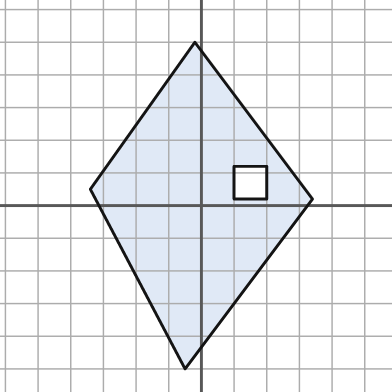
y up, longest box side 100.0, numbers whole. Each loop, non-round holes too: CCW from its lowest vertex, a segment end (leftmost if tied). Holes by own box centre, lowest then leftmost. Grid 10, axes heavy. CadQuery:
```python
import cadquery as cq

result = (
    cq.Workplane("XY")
    .moveTo(-5.0, -50.0)
    .lineTo(34.0, 2.0)
    .lineTo(-2.0, 50.0)
    .lineTo(-34.0, 5.0)
    .close()
    .moveTo(10.0, 2.0)
    .lineTo(20.0, 2.0)
    .lineTo(20.0, 12.0)
    .lineTo(10.0, 12.0)
    .close()
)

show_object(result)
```